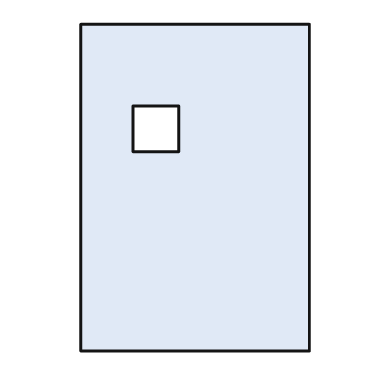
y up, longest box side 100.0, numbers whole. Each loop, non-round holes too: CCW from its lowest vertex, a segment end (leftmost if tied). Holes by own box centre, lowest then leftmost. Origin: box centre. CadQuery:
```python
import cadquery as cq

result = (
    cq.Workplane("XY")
    .moveTo(-35.0, -50.0)
    .lineTo(35.0, -50.0)
    .lineTo(35.0, 50.0)
    .lineTo(-35.0, 50.0)
    .close()
    .moveTo(-19.0, 11.0)
    .lineTo(-5.0, 11.0)
    .lineTo(-5.0, 25.0)
    .lineTo(-19.0, 25.0)
    .close()
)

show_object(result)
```